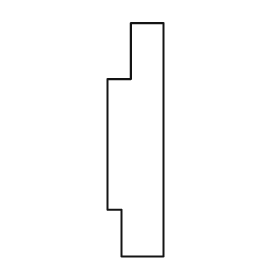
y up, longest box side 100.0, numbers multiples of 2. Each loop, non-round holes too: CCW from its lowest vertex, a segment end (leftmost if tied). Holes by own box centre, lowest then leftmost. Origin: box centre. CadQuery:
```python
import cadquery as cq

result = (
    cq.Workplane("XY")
    .moveTo(-6.0, -50.0)
    .lineTo(12.0, -50.0)
    .lineTo(12.0, 50.0)
    .lineTo(-2.0, 50.0)
    .lineTo(-2.0, 26.0)
    .lineTo(-12.0, 26.0)
    .lineTo(-12.0, -30.0)
    .lineTo(-6.0, -30.0)
    .close()
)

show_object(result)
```